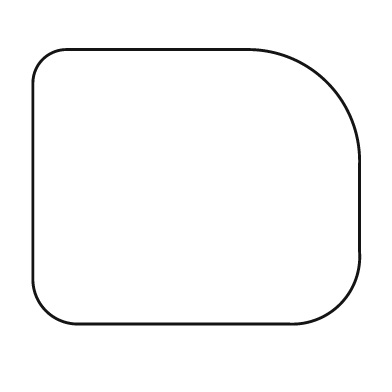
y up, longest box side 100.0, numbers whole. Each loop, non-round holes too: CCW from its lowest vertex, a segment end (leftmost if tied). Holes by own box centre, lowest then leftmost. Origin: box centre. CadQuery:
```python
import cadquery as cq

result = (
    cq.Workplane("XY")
    .moveTo(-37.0, -42.0)
    .lineTo(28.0, -42.0)
    .threePointArc((44.0, -36.0), (50.0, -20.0))
    .lineTo(50.0, 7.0)
    .threePointArc((40.0, 32.0), (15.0, 42.0))
    .lineTo(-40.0, 42.0)
    .threePointArc((-47.0, 39.0), (-50.0, 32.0))
    .lineTo(-50.0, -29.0)
    .threePointArc((-46.0, -38.0), (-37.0, -42.0))
    .close()
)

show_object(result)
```